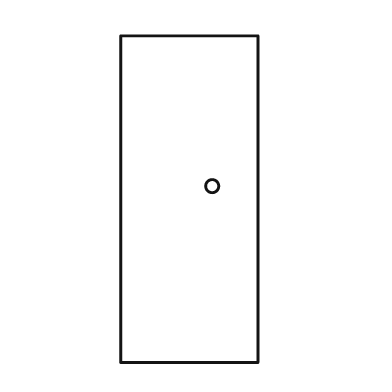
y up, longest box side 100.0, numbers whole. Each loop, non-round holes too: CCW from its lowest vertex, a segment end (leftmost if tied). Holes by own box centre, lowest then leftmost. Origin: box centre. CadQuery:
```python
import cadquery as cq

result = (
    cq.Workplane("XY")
    .moveTo(-21.0, -50.0)
    .lineTo(21.0, -50.0)
    .lineTo(21.0, 50.0)
    .lineTo(-21.0, 50.0)
    .close()
    .moveTo(7.0, 4.0)
    .circle(2.0)
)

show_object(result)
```